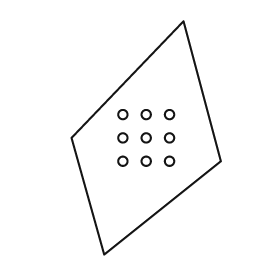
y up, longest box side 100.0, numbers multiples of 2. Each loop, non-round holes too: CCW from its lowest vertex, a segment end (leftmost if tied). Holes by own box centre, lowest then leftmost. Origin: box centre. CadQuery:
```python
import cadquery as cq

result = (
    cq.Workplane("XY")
    .moveTo(-18.0, -50.0)
    .lineTo(32.0, -10.0)
    .lineTo(16.0, 50.0)
    .lineTo(-32.0, 0.0)
    .close()
    .moveTo(-10.0, -10.0)
    .circle(2.0)
    .moveTo(0.0, -10.0)
    .circle(2.0)
    .moveTo(10.0, -10.0)
    .circle(2.0)
    .moveTo(-10.0, 0.0)
    .circle(2.0)
    .moveTo(0.0, 0.0)
    .circle(2.0)
    .moveTo(10.0, 0.0)
    .circle(2.0)
    .moveTo(-10.0, 10.0)
    .circle(2.0)
    .moveTo(0.0, 10.0)
    .circle(2.0)
    .moveTo(10.0, 10.0)
    .circle(2.0)
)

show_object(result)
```